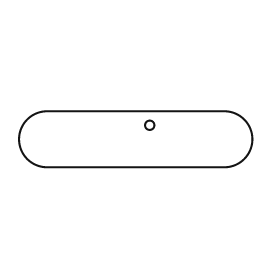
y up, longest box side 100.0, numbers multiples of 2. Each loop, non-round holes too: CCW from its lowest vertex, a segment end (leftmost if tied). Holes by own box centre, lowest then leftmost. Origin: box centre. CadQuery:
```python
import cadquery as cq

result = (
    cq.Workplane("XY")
    .moveTo(-38.0, -12.0)
    .lineTo(38.0, -12.0)
    .threePointArc((50.0, 0.0), (38.0, 12.0))
    .lineTo(-38.0, 12.0)
    .threePointArc((-50.0, 0.0), (-38.0, -12.0))
    .close()
    .moveTo(6.0, 6.0)
    .circle(2.0)
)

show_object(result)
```